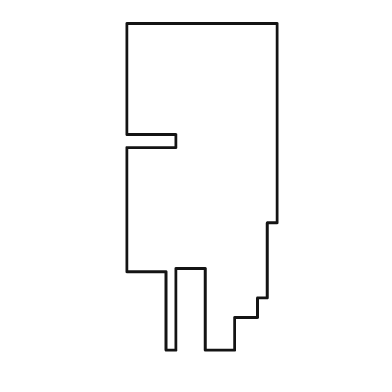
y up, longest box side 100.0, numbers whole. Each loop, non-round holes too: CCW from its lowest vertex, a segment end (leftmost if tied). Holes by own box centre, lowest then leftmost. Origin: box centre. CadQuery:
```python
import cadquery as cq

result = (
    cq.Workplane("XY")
    .moveTo(-11.0, -50.0)
    .lineTo(-8.0, -50.0)
    .lineTo(-8.0, -25.0)
    .lineTo(1.0, -25.0)
    .lineTo(1.0, -50.0)
    .lineTo(10.0, -50.0)
    .lineTo(10.0, -40.0)
    .lineTo(17.0, -40.0)
    .lineTo(17.0, -34.0)
    .lineTo(20.0, -34.0)
    .lineTo(20.0, -11.0)
    .lineTo(23.0, -11.0)
    .lineTo(23.0, 50.0)
    .lineTo(-23.0, 50.0)
    .lineTo(-23.0, 16.0)
    .lineTo(-8.0, 16.0)
    .lineTo(-8.0, 12.0)
    .lineTo(-23.0, 12.0)
    .lineTo(-23.0, -26.0)
    .lineTo(-11.0, -26.0)
    .close()
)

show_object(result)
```